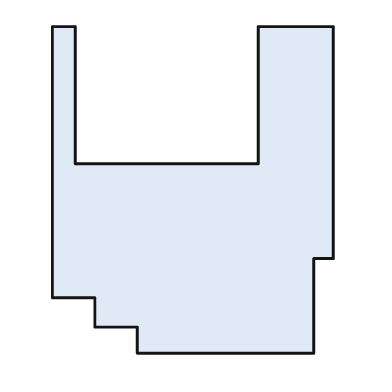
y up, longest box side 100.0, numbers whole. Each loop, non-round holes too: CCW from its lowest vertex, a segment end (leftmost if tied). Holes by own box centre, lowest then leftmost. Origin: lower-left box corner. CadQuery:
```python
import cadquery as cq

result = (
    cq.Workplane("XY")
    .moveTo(26.0, 0.0)
    .lineTo(80.0, 0.0)
    .lineTo(80.0, 29.0)
    .lineTo(86.0, 29.0)
    .lineTo(86.0, 100.0)
    .lineTo(63.0, 100.0)
    .lineTo(63.0, 58.0)
    .lineTo(7.0, 58.0)
    .lineTo(7.0, 100.0)
    .lineTo(0.0, 100.0)
    .lineTo(0.0, 17.0)
    .lineTo(13.0, 17.0)
    .lineTo(13.0, 8.0)
    .lineTo(26.0, 8.0)
    .close()
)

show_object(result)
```